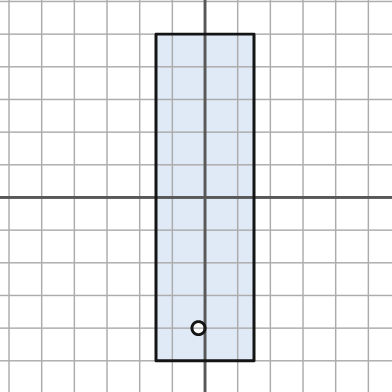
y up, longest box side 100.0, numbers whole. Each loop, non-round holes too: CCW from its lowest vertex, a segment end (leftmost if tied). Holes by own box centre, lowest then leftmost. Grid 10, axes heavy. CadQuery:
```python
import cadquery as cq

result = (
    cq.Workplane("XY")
    .moveTo(-15.0, -50.0)
    .lineTo(15.0, -50.0)
    .lineTo(15.0, 50.0)
    .lineTo(-15.0, 50.0)
    .close()
    .moveTo(-2.0, -40.0)
    .circle(2.0)
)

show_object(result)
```